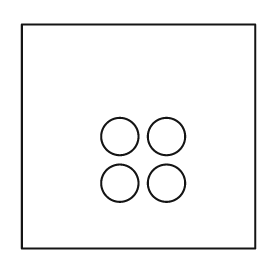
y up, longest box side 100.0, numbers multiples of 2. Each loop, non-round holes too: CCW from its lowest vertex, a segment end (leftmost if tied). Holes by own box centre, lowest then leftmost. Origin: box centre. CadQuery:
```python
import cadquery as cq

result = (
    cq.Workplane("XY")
    .moveTo(-50.0, -48.0)
    .lineTo(50.0, -48.0)
    .lineTo(50.0, 48.0)
    .lineTo(-50.0, 48.0)
    .close()
    .moveTo(-8.0, -20.0)
    .circle(8.0)
    .moveTo(12.0, -20.0)
    .circle(8.0)
    .moveTo(-8.0, 0.0)
    .circle(8.0)
    .moveTo(12.0, 0.0)
    .circle(8.0)
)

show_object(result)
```